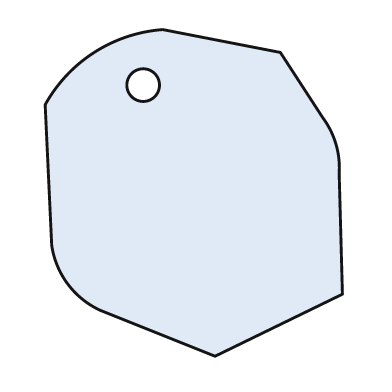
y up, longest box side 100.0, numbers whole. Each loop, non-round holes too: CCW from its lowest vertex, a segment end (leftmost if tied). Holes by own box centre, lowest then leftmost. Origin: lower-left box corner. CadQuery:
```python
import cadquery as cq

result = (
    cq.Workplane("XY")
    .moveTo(52.0, 0.0)
    .lineTo(91.0, 19.0)
    .lineTo(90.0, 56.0)
    .threePointArc((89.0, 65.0), (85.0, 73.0))
    .lineTo(72.0, 93.0)
    .lineTo(36.0, 100.0)
    .threePointArc((15.0, 93.0), (0.0, 77.0))
    .lineTo(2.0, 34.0)
    .threePointArc((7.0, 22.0), (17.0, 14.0))
    .close()
    .moveTo(30.0, 83.0)
    .circle(5.0)
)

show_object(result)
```